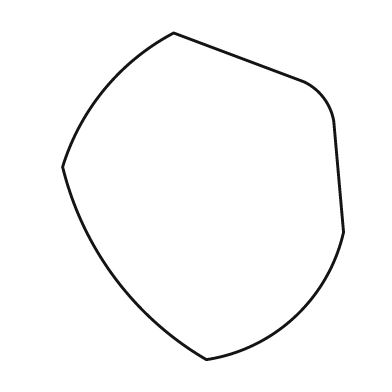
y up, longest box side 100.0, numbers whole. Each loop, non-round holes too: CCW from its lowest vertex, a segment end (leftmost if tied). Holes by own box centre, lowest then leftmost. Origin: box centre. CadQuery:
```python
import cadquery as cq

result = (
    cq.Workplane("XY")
    .moveTo(1.0, -50.0)
    .threePointArc((28.0, -37.0), (43.0, -11.0))
    .lineTo(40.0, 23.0)
    .threePointArc((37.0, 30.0), (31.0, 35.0))
    .lineTo(-9.0, 50.0)
    .threePointArc((-30.0, 33.0), (-43.0, 9.0))
    .threePointArc((-27.0, -25.0), (1.0, -50.0))
    .close()
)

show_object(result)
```